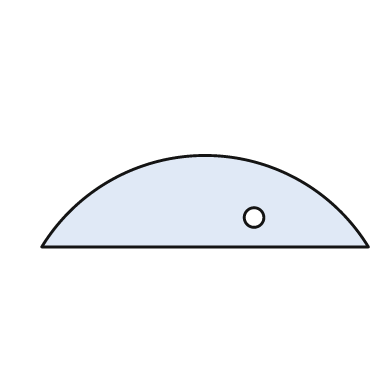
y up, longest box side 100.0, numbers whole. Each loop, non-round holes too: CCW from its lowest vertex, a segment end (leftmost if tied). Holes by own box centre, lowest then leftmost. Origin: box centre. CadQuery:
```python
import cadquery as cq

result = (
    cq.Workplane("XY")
    .moveTo(-50.0, -14.0)
    .lineTo(50.0, -14.0)
    .threePointArc((0.0, 14.0), (-50.0, -14.0))
    .close()
    .moveTo(15.0, -5.0)
    .circle(3.0)
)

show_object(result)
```